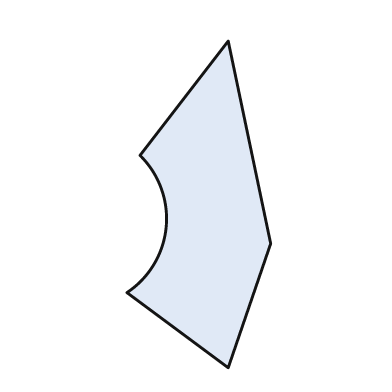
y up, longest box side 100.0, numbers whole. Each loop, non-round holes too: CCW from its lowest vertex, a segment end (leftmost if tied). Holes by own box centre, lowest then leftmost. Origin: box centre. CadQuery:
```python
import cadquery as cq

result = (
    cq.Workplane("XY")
    .moveTo(9.0, -50.0)
    .lineTo(22.0, -12.0)
    .lineTo(9.0, 50.0)
    .lineTo(-18.0, 15.0)
    .threePointArc((-10.0, -7.0), (-22.0, -27.0))
    .close()
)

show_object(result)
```